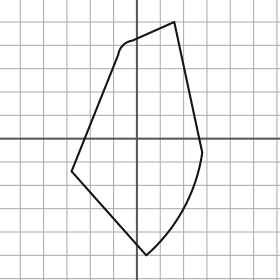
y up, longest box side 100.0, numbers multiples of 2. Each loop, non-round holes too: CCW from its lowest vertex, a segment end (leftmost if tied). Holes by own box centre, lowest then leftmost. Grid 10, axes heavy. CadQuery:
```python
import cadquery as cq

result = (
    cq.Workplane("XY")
    .moveTo(4.0, -50.0)
    .threePointArc((20.0, -30.0), (28.0, -6.0))
    .lineTo(16.0, 50.0)
    .lineTo(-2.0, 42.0)
    .threePointArc((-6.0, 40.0), (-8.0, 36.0))
    .lineTo(-28.0, -14.0)
    .close()
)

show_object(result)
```